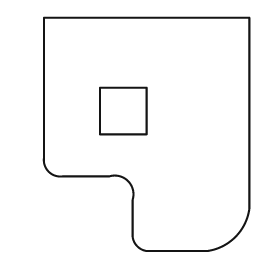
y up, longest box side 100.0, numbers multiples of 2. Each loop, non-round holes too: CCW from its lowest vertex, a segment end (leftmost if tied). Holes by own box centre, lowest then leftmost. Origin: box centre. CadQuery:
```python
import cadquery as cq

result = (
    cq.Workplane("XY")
    .moveTo(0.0, -50.0)
    .lineTo(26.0, -50.0)
    .threePointArc((38.0, -44.0), (44.0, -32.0))
    .lineTo(44.0, 50.0)
    .lineTo(-44.0, 50.0)
    .lineTo(-44.0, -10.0)
    .threePointArc((-42.0, -16.0), (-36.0, -18.0))
    .lineTo(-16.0, -18.0)
    .threePointArc((-8.0, -20.0), (-6.0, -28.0))
    .lineTo(-6.0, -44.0)
    .threePointArc((-4.0, -48.0), (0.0, -50.0))
    .close()
    .moveTo(-20.0, 0.0)
    .lineTo(0.0, 0.0)
    .lineTo(0.0, 20.0)
    .lineTo(-20.0, 20.0)
    .close()
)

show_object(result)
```